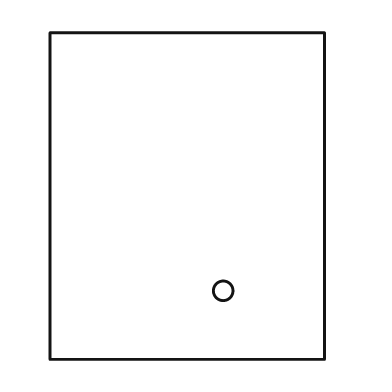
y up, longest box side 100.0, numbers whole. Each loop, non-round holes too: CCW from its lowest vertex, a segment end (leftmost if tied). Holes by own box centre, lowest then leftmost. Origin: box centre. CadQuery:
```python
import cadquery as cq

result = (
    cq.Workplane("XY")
    .moveTo(-42.0, -50.0)
    .lineTo(42.0, -50.0)
    .lineTo(42.0, 50.0)
    .lineTo(-42.0, 50.0)
    .close()
    .moveTo(11.0, -29.0)
    .circle(3.0)
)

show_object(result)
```